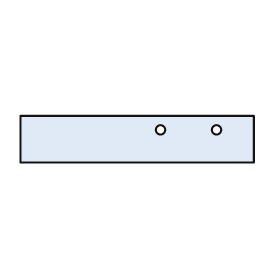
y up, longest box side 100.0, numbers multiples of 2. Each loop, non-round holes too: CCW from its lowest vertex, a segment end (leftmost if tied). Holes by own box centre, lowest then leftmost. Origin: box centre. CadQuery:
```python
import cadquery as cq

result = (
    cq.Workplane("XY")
    .moveTo(-50.0, -10.0)
    .lineTo(50.0, -10.0)
    .lineTo(50.0, 10.0)
    .lineTo(-50.0, 10.0)
    .close()
    .moveTo(10.0, 4.0)
    .circle(2.0)
    .moveTo(34.0, 4.0)
    .circle(2.0)
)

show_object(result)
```